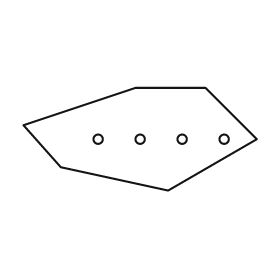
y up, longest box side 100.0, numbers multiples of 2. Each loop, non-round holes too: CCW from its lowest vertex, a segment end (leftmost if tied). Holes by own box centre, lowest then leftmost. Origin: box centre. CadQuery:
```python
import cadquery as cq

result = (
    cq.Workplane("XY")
    .moveTo(12.0, -22.0)
    .lineTo(50.0, 0.0)
    .lineTo(28.0, 22.0)
    .lineTo(-2.0, 22.0)
    .lineTo(-50.0, 6.0)
    .lineTo(-34.0, -12.0)
    .close()
    .moveTo(-18.0, 0.0)
    .circle(2.0)
    .moveTo(0.0, 0.0)
    .circle(2.0)
    .moveTo(18.0, 0.0)
    .circle(2.0)
    .moveTo(36.0, 0.0)
    .circle(2.0)
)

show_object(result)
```